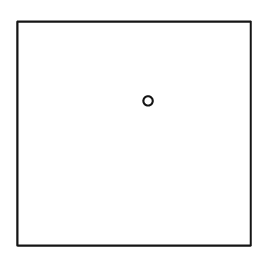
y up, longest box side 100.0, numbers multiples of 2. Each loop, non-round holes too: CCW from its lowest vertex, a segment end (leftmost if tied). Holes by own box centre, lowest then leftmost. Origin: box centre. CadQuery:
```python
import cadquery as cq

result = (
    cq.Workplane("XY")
    .moveTo(-50.0, -48.0)
    .lineTo(50.0, -48.0)
    .lineTo(50.0, 48.0)
    .lineTo(-50.0, 48.0)
    .close()
    .moveTo(6.0, 14.0)
    .circle(2.0)
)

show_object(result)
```